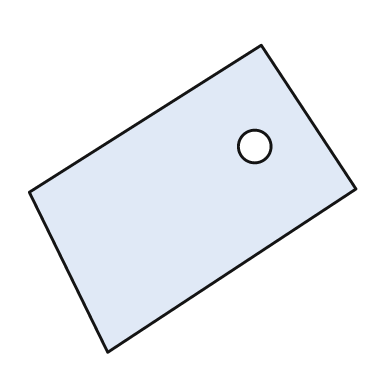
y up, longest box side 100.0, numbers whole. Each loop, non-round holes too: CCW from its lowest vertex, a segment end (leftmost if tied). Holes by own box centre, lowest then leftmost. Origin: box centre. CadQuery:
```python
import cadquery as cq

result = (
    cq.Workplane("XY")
    .moveTo(-26.0, -47.0)
    .lineTo(50.0, 3.0)
    .lineTo(21.0, 47.0)
    .lineTo(-50.0, 2.0)
    .close()
    .moveTo(19.0, 16.0)
    .circle(5.0)
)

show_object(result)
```